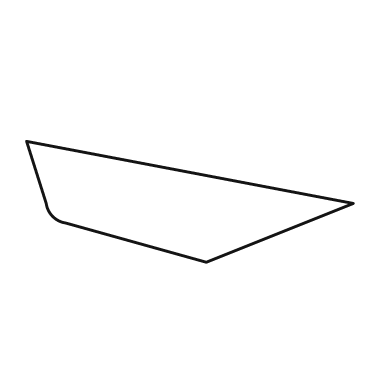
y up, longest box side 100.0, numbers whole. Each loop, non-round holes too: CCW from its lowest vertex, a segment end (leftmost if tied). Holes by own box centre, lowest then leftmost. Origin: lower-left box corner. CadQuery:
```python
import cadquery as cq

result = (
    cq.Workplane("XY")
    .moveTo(55.0, 0.0)
    .lineTo(100.0, 18.0)
    .lineTo(0.0, 37.0)
    .lineTo(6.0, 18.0)
    .threePointArc((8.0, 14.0), (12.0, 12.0))
    .close()
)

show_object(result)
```